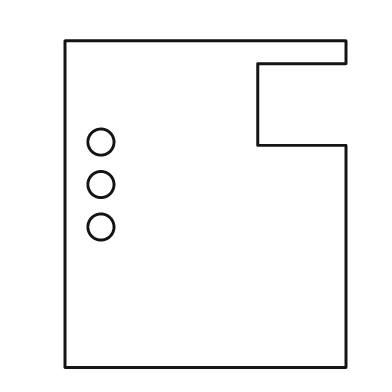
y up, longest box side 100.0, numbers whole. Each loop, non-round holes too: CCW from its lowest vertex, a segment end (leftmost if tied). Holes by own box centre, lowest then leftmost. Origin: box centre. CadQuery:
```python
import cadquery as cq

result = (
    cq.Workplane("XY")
    .moveTo(-43.0, -50.0)
    .lineTo(43.0, -50.0)
    .lineTo(43.0, 18.0)
    .lineTo(16.0, 18.0)
    .lineTo(16.0, 43.0)
    .lineTo(43.0, 43.0)
    .lineTo(43.0, 50.0)
    .lineTo(-43.0, 50.0)
    .close()
    .moveTo(-32.0, -7.0)
    .circle(4.0)
    .moveTo(-32.0, 6.0)
    .circle(4.0)
    .moveTo(-32.0, 19.0)
    .circle(4.0)
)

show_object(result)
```